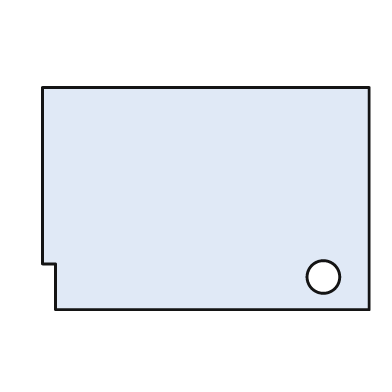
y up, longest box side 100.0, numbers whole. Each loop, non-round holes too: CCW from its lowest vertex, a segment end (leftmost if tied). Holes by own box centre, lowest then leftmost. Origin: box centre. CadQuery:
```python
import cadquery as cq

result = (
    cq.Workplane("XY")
    .moveTo(-46.0, -34.0)
    .lineTo(50.0, -34.0)
    .lineTo(50.0, 34.0)
    .lineTo(-50.0, 34.0)
    .lineTo(-50.0, -20.0)
    .lineTo(-46.0, -20.0)
    .close()
    .moveTo(36.0, -24.0)
    .circle(5.0)
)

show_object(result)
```